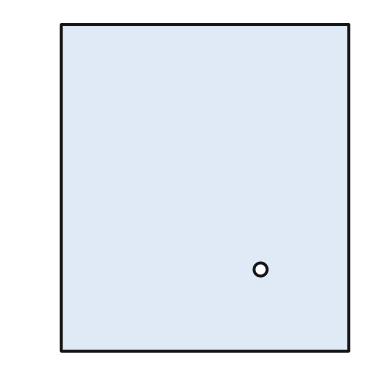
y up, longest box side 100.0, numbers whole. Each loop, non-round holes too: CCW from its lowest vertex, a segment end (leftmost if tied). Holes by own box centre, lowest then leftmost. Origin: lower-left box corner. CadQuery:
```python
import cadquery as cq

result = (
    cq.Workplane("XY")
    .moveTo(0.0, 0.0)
    .lineTo(88.0, 0.0)
    .lineTo(88.0, 100.0)
    .lineTo(0.0, 100.0)
    .close()
    .moveTo(61.0, 25.0)
    .circle(2.0)
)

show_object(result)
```